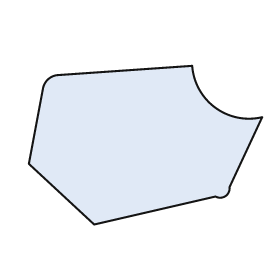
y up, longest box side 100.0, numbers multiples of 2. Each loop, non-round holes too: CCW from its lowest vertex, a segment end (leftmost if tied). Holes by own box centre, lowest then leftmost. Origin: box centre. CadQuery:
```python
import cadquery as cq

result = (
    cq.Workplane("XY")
    .moveTo(-22.0, -34.0)
    .lineTo(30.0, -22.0)
    .threePointArc((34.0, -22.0), (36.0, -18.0))
    .lineTo(50.0, 12.0)
    .threePointArc((30.0, 16.0), (20.0, 34.0))
    .lineTo(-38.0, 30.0)
    .threePointArc((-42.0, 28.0), (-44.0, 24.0))
    .lineTo(-50.0, -8.0)
    .close()
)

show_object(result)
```